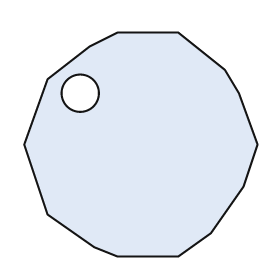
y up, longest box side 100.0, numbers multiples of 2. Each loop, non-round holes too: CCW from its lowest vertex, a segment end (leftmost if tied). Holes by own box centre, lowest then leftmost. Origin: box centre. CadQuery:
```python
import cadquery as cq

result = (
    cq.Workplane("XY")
    .moveTo(-10.0, -48.0)
    .lineTo(16.0, -48.0)
    .lineTo(30.0, -38.0)
    .lineTo(44.0, -18.0)
    .lineTo(50.0, 0.0)
    .lineTo(42.0, 22.0)
    .lineTo(36.0, 32.0)
    .lineTo(16.0, 48.0)
    .lineTo(-10.0, 48.0)
    .lineTo(-22.0, 42.0)
    .lineTo(-40.0, 28.0)
    .lineTo(-50.0, 0.0)
    .lineTo(-40.0, -30.0)
    .lineTo(-20.0, -44.0)
    .close()
    .moveTo(-26.0, 22.0)
    .circle(8.0)
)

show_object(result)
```